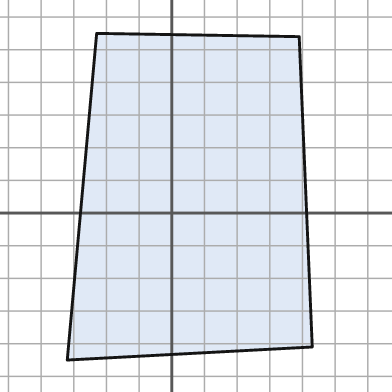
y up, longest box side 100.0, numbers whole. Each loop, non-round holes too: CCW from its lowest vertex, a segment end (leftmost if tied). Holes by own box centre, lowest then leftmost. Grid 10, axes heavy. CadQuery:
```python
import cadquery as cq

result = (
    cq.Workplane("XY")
    .moveTo(-32.0, -45.0)
    .lineTo(43.0, -41.0)
    .lineTo(39.0, 54.0)
    .lineTo(-23.0, 55.0)
    .close()
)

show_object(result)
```